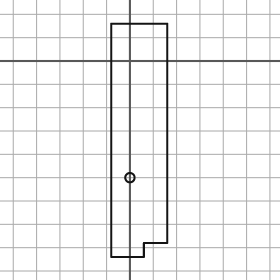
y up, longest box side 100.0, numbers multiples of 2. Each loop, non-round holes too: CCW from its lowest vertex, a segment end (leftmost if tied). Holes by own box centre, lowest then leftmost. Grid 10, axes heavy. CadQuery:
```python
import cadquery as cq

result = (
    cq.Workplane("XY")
    .moveTo(-8.0, -84.0)
    .lineTo(6.0, -84.0)
    .lineTo(6.0, -78.0)
    .lineTo(16.0, -78.0)
    .lineTo(16.0, 16.0)
    .lineTo(-8.0, 16.0)
    .close()
    .moveTo(0.0, -50.0)
    .circle(2.0)
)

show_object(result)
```